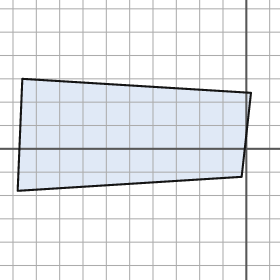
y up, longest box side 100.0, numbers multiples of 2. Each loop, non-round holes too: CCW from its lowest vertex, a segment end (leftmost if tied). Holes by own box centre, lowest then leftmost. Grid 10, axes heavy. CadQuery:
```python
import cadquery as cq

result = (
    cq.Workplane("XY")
    .moveTo(-98.0, -18.0)
    .lineTo(-2.0, -12.0)
    .lineTo(2.0, 24.0)
    .lineTo(-96.0, 30.0)
    .close()
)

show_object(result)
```